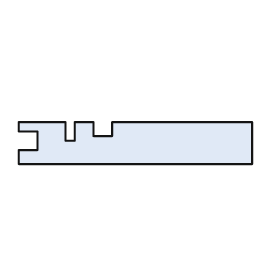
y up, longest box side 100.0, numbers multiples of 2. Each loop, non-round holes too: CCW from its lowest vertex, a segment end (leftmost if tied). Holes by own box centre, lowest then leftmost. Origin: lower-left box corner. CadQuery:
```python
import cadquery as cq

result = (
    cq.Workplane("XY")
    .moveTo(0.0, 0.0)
    .lineTo(100.0, 0.0)
    .lineTo(100.0, 18.0)
    .lineTo(40.0, 18.0)
    .lineTo(40.0, 12.0)
    .lineTo(32.0, 12.0)
    .lineTo(32.0, 18.0)
    .lineTo(24.0, 18.0)
    .lineTo(24.0, 10.0)
    .lineTo(20.0, 10.0)
    .lineTo(20.0, 18.0)
    .lineTo(0.0, 18.0)
    .lineTo(0.0, 14.0)
    .lineTo(8.0, 14.0)
    .lineTo(8.0, 6.0)
    .lineTo(0.0, 6.0)
    .close()
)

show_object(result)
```